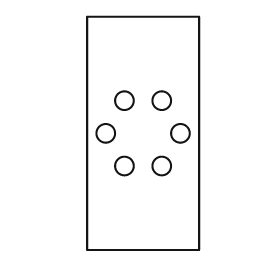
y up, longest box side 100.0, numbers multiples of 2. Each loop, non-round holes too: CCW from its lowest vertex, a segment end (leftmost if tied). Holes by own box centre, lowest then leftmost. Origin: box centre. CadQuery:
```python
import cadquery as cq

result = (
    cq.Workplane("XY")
    .moveTo(-24.0, -50.0)
    .lineTo(24.0, -50.0)
    .lineTo(24.0, 50.0)
    .lineTo(-24.0, 50.0)
    .close()
    .moveTo(-8.0, -14.0)
    .circle(4.0)
    .moveTo(8.0, -14.0)
    .circle(4.0)
    .moveTo(-16.0, 0.0)
    .circle(4.0)
    .moveTo(16.0, 0.0)
    .circle(4.0)
    .moveTo(-8.0, 14.0)
    .circle(4.0)
    .moveTo(8.0, 14.0)
    .circle(4.0)
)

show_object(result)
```